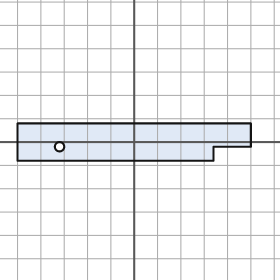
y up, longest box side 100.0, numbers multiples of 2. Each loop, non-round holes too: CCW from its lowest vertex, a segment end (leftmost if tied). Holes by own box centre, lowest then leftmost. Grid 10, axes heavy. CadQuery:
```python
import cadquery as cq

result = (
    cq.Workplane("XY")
    .moveTo(-50.0, -8.0)
    .lineTo(34.0, -8.0)
    .lineTo(34.0, -2.0)
    .lineTo(50.0, -2.0)
    .lineTo(50.0, 8.0)
    .lineTo(-50.0, 8.0)
    .close()
    .moveTo(-32.0, -2.0)
    .circle(2.0)
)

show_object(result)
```